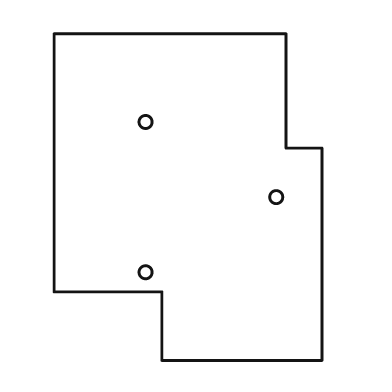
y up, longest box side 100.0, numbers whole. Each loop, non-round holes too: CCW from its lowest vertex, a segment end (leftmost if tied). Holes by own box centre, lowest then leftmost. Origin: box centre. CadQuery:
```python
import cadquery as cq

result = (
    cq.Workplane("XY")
    .moveTo(-8.0, -50.0)
    .lineTo(41.0, -50.0)
    .lineTo(41.0, 15.0)
    .lineTo(30.0, 15.0)
    .lineTo(30.0, 50.0)
    .lineTo(-41.0, 50.0)
    .lineTo(-41.0, -29.0)
    .lineTo(-8.0, -29.0)
    .close()
    .moveTo(-13.0, -23.0)
    .circle(2.0)
    .moveTo(27.0, 0.0)
    .circle(2.0)
    .moveTo(-13.0, 23.0)
    .circle(2.0)
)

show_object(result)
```